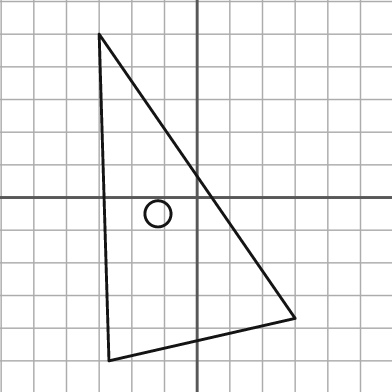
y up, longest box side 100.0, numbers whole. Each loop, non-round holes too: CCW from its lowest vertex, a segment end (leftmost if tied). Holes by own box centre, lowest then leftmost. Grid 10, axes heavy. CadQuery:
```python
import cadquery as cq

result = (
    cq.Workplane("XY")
    .moveTo(-27.0, -50.0)
    .lineTo(30.0, -37.0)
    .lineTo(-30.0, 50.0)
    .close()
    .moveTo(-12.0, -5.0)
    .circle(4.0)
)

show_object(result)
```